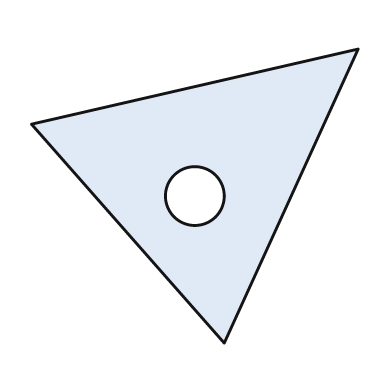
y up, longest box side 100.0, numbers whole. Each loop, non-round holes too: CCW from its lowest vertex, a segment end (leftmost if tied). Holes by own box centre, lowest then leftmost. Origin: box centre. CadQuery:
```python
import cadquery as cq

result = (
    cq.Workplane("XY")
    .moveTo(9.0, -45.0)
    .lineTo(50.0, 45.0)
    .lineTo(-50.0, 22.0)
    .close()
    .moveTo(0.0, 0.0)
    .circle(9.0)
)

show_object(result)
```